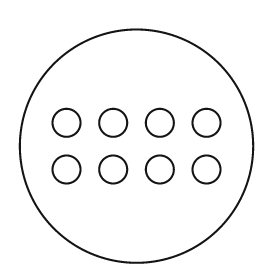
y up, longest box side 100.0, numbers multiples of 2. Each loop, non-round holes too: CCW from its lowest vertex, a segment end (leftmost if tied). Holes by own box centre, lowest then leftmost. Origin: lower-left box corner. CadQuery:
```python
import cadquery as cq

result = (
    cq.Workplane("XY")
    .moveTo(50.0, 50.0)
    .circle(50.0)
    .moveTo(20.0, 40.0)
    .circle(6.0)
    .moveTo(40.0, 40.0)
    .circle(6.0)
    .moveTo(60.0, 40.0)
    .circle(6.0)
    .moveTo(80.0, 40.0)
    .circle(6.0)
    .moveTo(20.0, 60.0)
    .circle(6.0)
    .moveTo(40.0, 60.0)
    .circle(6.0)
    .moveTo(60.0, 60.0)
    .circle(6.0)
    .moveTo(80.0, 60.0)
    .circle(6.0)
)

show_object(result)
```